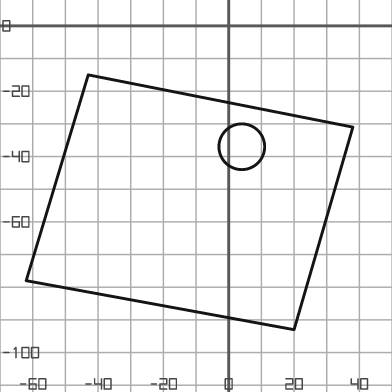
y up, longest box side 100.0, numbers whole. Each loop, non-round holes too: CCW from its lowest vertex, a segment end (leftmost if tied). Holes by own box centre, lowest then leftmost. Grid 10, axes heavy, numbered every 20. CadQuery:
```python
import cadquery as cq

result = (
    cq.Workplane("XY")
    .moveTo(20.0, -93.0)
    .lineTo(38.0, -31.0)
    .lineTo(-43.0, -15.0)
    .lineTo(-62.0, -78.0)
    .close()
    .moveTo(4.0, -37.0)
    .circle(7.0)
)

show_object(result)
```